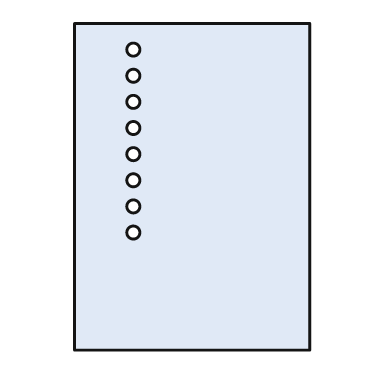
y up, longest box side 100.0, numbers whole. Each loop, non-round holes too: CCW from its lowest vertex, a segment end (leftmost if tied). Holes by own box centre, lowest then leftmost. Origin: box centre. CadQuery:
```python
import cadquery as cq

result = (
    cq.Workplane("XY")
    .moveTo(-36.0, -50.0)
    .lineTo(36.0, -50.0)
    .lineTo(36.0, 50.0)
    .lineTo(-36.0, 50.0)
    .close()
    .moveTo(-18.0, -14.0)
    .circle(2.0)
    .moveTo(-18.0, -6.0)
    .circle(2.0)
    .moveTo(-18.0, 2.0)
    .circle(2.0)
    .moveTo(-18.0, 10.0)
    .circle(2.0)
    .moveTo(-18.0, 18.0)
    .circle(2.0)
    .moveTo(-18.0, 26.0)
    .circle(2.0)
    .moveTo(-18.0, 34.0)
    .circle(2.0)
    .moveTo(-18.0, 42.0)
    .circle(2.0)
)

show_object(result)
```